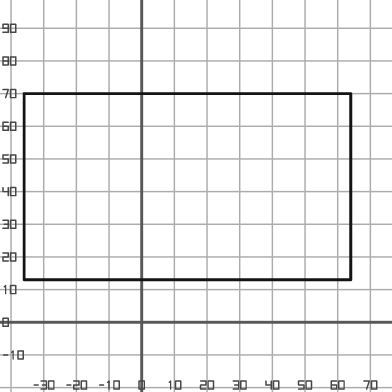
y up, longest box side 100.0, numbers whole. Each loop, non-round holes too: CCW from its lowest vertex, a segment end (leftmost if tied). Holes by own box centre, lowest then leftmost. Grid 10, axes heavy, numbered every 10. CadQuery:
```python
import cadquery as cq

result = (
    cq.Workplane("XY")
    .moveTo(-36.0, 13.0)
    .lineTo(64.0, 13.0)
    .lineTo(64.0, 70.0)
    .lineTo(-36.0, 70.0)
    .close()
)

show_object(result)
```